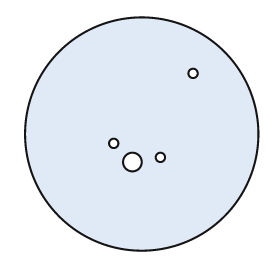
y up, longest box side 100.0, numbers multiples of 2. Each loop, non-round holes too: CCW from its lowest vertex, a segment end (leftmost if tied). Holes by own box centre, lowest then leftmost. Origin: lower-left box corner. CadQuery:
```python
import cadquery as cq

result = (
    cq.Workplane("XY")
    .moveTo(50.0, 50.0)
    .circle(50.0)
    .moveTo(46.0, 38.0)
    .circle(4.0)
    .moveTo(58.0, 40.0)
    .circle(2.0)
    .moveTo(38.0, 46.0)
    .circle(2.0)
    .moveTo(72.0, 76.0)
    .circle(2.0)
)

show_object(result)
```